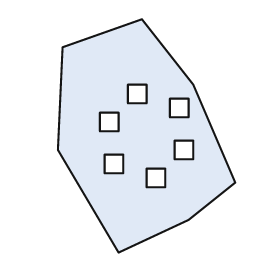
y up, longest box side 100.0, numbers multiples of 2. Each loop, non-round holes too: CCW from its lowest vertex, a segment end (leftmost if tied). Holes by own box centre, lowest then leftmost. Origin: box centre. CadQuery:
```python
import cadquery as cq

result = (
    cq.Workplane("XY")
    .moveTo(-12.0, -50.0)
    .lineTo(18.0, -36.0)
    .lineTo(38.0, -20.0)
    .lineTo(20.0, 22.0)
    .lineTo(-2.0, 50.0)
    .lineTo(-36.0, 38.0)
    .lineTo(-38.0, -6.0)
    .close()
    .moveTo(0.0, -22.0)
    .lineTo(8.0, -22.0)
    .lineTo(8.0, -14.0)
    .lineTo(0.0, -14.0)
    .close()
    .moveTo(-18.0, -16.0)
    .lineTo(-10.0, -16.0)
    .lineTo(-10.0, -8.0)
    .lineTo(-18.0, -8.0)
    .close()
    .moveTo(12.0, -10.0)
    .lineTo(20.0, -10.0)
    .lineTo(20.0, -2.0)
    .lineTo(12.0, -2.0)
    .close()
    .moveTo(-20.0, 2.0)
    .lineTo(-12.0, 2.0)
    .lineTo(-12.0, 10.0)
    .lineTo(-20.0, 10.0)
    .close()
    .moveTo(10.0, 8.0)
    .lineTo(18.0, 8.0)
    .lineTo(18.0, 16.0)
    .lineTo(10.0, 16.0)
    .close()
    .moveTo(-8.0, 14.0)
    .lineTo(0.0, 14.0)
    .lineTo(0.0, 22.0)
    .lineTo(-8.0, 22.0)
    .close()
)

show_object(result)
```